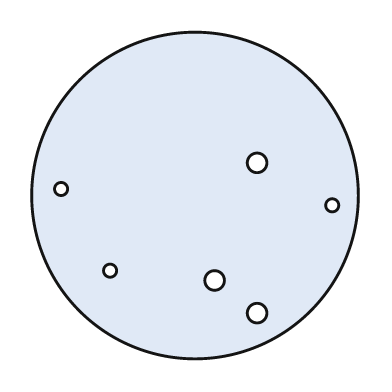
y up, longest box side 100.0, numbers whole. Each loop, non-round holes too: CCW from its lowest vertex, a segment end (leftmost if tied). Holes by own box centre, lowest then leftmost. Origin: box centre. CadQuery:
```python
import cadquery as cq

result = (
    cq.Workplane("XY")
    .moveTo(0.0, 0.0)
    .circle(50.0)
    .moveTo(19.0, -36.0)
    .circle(3.0)
    .moveTo(6.0, -26.0)
    .circle(3.0)
    .moveTo(-26.0, -23.0)
    .circle(2.0)
    .moveTo(42.0, -3.0)
    .circle(2.0)
    .moveTo(-41.0, 2.0)
    .circle(2.0)
    .moveTo(19.0, 10.0)
    .circle(3.0)
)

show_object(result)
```